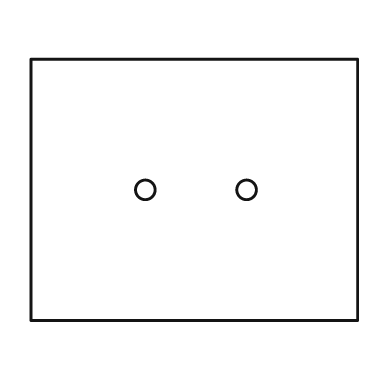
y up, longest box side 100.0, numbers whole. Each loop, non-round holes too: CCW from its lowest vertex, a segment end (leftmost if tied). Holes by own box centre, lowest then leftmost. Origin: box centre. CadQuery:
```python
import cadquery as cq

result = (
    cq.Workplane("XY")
    .moveTo(-50.0, -40.0)
    .lineTo(50.0, -40.0)
    .lineTo(50.0, 40.0)
    .lineTo(-50.0, 40.0)
    .close()
    .moveTo(-15.0, 0.0)
    .circle(3.0)
    .moveTo(16.0, 0.0)
    .circle(3.0)
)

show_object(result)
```